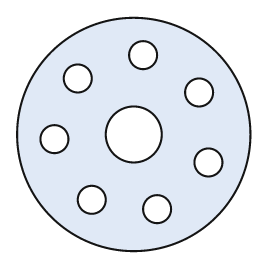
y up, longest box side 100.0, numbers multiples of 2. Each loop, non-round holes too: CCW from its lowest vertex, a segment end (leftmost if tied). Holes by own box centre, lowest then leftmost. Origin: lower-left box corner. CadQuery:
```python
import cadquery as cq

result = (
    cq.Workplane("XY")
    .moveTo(50.0, 50.0)
    .circle(50.0)
    .moveTo(60.0, 18.0)
    .circle(6.0)
    .moveTo(32.0, 22.0)
    .circle(6.0)
    .moveTo(82.0, 38.0)
    .circle(6.0)
    .moveTo(16.0, 48.0)
    .circle(6.0)
    .moveTo(50.0, 50.0)
    .circle(12.0)
    .moveTo(78.0, 68.0)
    .circle(6.0)
    .moveTo(26.0, 74.0)
    .circle(6.0)
    .moveTo(54.0, 84.0)
    .circle(6.0)
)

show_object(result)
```